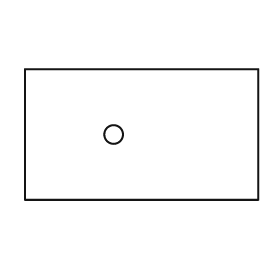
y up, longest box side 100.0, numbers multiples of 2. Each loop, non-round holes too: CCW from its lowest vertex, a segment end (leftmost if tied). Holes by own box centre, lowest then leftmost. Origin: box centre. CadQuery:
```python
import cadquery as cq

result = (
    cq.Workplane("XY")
    .moveTo(-50.0, -28.0)
    .lineTo(50.0, -28.0)
    .lineTo(50.0, 28.0)
    .lineTo(-50.0, 28.0)
    .close()
    .moveTo(-12.0, 0.0)
    .circle(4.0)
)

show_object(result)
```